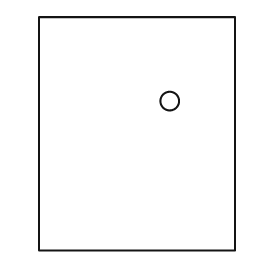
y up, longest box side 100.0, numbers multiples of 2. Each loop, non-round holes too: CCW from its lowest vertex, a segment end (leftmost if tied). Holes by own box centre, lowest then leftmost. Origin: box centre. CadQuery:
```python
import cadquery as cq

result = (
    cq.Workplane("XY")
    .moveTo(-42.0, -50.0)
    .lineTo(42.0, -50.0)
    .lineTo(42.0, 50.0)
    .lineTo(-42.0, 50.0)
    .close()
    .moveTo(14.0, 14.0)
    .circle(4.0)
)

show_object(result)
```